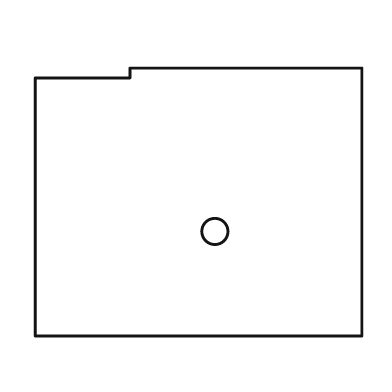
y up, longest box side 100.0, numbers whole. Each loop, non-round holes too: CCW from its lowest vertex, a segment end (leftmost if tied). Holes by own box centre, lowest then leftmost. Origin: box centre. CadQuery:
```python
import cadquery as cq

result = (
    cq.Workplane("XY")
    .moveTo(-50.0, -41.0)
    .lineTo(50.0, -41.0)
    .lineTo(50.0, 41.0)
    .lineTo(-21.0, 41.0)
    .lineTo(-21.0, 38.0)
    .lineTo(-50.0, 38.0)
    .close()
    .moveTo(5.0, -9.0)
    .circle(4.0)
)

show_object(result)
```